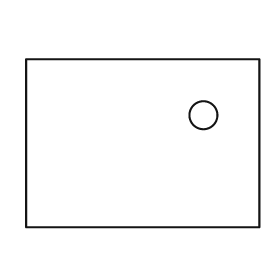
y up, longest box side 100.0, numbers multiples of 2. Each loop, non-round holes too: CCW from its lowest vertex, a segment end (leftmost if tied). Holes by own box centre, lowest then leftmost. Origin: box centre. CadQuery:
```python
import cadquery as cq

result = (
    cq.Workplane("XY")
    .moveTo(-50.0, -36.0)
    .lineTo(50.0, -36.0)
    .lineTo(50.0, 36.0)
    .lineTo(-50.0, 36.0)
    .close()
    .moveTo(26.0, 12.0)
    .circle(6.0)
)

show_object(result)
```